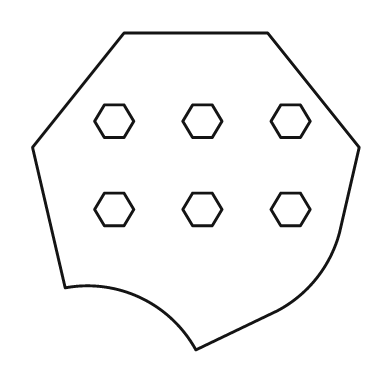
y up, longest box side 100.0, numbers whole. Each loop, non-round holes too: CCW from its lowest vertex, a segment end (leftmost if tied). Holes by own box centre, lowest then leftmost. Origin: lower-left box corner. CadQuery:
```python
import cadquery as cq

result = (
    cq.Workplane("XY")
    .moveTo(50.0, 0.0)
    .lineTo(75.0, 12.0)
    .threePointArc((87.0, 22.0), (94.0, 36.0))
    .lineTo(100.0, 62.0)
    .lineTo(72.0, 97.0)
    .lineTo(28.0, 97.0)
    .lineTo(0.0, 62.0)
    .lineTo(10.0, 19.0)
    .threePointArc((33.0, 16.0), (50.0, 0.0))
    .close()
    .moveTo(22.0, 38.0)
    .lineTo(28.0, 38.0)
    .lineTo(31.0, 43.0)
    .lineTo(28.0, 48.0)
    .lineTo(22.0, 48.0)
    .lineTo(19.0, 43.0)
    .close()
    .moveTo(49.0, 38.0)
    .lineTo(55.0, 38.0)
    .lineTo(58.0, 43.0)
    .lineTo(55.0, 48.0)
    .lineTo(49.0, 48.0)
    .lineTo(46.0, 43.0)
    .close()
    .moveTo(76.0, 38.0)
    .lineTo(82.0, 38.0)
    .lineTo(85.0, 43.0)
    .lineTo(82.0, 48.0)
    .lineTo(76.0, 48.0)
    .lineTo(73.0, 43.0)
    .close()
    .moveTo(22.0, 65.0)
    .lineTo(28.0, 65.0)
    .lineTo(31.0, 70.0)
    .lineTo(28.0, 75.0)
    .lineTo(22.0, 75.0)
    .lineTo(19.0, 70.0)
    .close()
    .moveTo(49.0, 65.0)
    .lineTo(55.0, 65.0)
    .lineTo(58.0, 70.0)
    .lineTo(55.0, 75.0)
    .lineTo(49.0, 75.0)
    .lineTo(46.0, 70.0)
    .close()
    .moveTo(76.0, 65.0)
    .lineTo(82.0, 65.0)
    .lineTo(85.0, 70.0)
    .lineTo(82.0, 75.0)
    .lineTo(76.0, 75.0)
    .lineTo(73.0, 70.0)
    .close()
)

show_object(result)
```